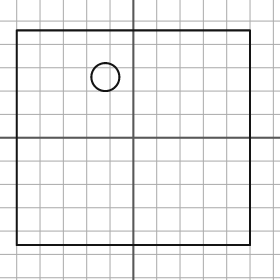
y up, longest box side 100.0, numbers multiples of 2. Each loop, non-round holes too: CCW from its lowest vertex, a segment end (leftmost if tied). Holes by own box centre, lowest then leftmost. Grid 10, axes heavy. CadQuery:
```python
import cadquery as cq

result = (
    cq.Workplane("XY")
    .moveTo(-50.0, -46.0)
    .lineTo(50.0, -46.0)
    .lineTo(50.0, 46.0)
    .lineTo(-50.0, 46.0)
    .close()
    .moveTo(-12.0, 26.0)
    .circle(6.0)
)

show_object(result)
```